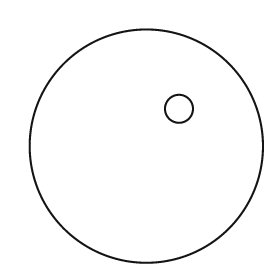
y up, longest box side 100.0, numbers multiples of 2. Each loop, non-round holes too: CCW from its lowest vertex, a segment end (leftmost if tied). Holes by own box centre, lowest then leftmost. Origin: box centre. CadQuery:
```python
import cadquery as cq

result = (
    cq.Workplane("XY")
    .moveTo(0.0, 0.0)
    .circle(50.0)
    .moveTo(14.0, 16.0)
    .circle(6.0)
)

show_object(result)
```